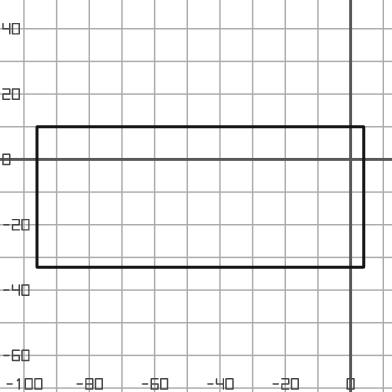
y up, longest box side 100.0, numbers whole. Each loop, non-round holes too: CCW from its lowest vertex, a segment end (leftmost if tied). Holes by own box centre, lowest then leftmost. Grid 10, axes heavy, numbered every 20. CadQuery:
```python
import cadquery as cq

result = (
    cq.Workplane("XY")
    .moveTo(-96.0, -33.0)
    .lineTo(4.0, -33.0)
    .lineTo(4.0, 10.0)
    .lineTo(-96.0, 10.0)
    .close()
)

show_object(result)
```